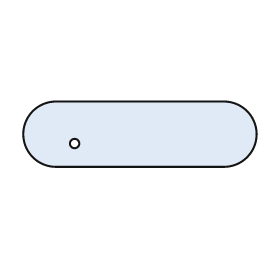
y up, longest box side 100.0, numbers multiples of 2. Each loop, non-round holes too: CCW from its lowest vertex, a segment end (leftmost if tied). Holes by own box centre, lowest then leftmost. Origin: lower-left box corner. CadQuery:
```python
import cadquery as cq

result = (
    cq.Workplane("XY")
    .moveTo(14.0, 0.0)
    .lineTo(86.0, 0.0)
    .threePointArc((100.0, 14.0), (86.0, 28.0))
    .lineTo(14.0, 28.0)
    .threePointArc((0.0, 14.0), (14.0, 0.0))
    .close()
    .moveTo(22.0, 10.0)
    .circle(2.0)
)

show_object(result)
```